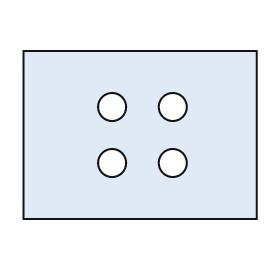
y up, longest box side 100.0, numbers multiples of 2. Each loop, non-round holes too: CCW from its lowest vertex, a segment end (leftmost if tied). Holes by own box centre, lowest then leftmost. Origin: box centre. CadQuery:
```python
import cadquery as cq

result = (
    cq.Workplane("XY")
    .moveTo(-50.0, -36.0)
    .lineTo(50.0, -36.0)
    .lineTo(50.0, 36.0)
    .lineTo(-50.0, 36.0)
    .close()
    .moveTo(-12.0, -12.0)
    .circle(6.0)
    .moveTo(14.0, -12.0)
    .circle(6.0)
    .moveTo(-12.0, 12.0)
    .circle(6.0)
    .moveTo(14.0, 12.0)
    .circle(6.0)
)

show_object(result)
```